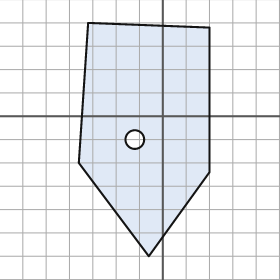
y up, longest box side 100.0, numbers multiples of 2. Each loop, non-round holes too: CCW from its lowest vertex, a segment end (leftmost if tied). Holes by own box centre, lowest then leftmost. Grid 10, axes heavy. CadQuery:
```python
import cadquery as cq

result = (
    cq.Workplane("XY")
    .moveTo(-6.0, -60.0)
    .lineTo(20.0, -24.0)
    .lineTo(20.0, 38.0)
    .lineTo(-32.0, 40.0)
    .lineTo(-36.0, -20.0)
    .close()
    .moveTo(-12.0, -10.0)
    .circle(4.0)
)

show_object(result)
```